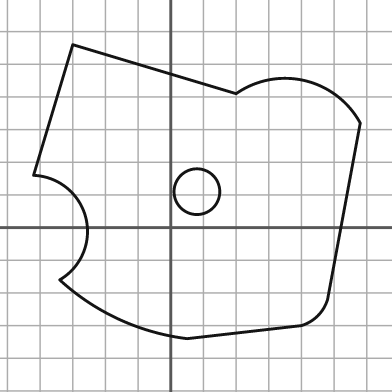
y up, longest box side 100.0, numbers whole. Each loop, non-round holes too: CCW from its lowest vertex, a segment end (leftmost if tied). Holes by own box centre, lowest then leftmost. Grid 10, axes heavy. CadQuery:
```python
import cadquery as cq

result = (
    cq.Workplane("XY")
    .moveTo(5.0, -34.0)
    .lineTo(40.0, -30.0)
    .threePointArc((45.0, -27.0), (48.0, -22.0))
    .lineTo(58.0, 32.0)
    .threePointArc((41.0, 45.0), (20.0, 41.0))
    .lineTo(-30.0, 56.0)
    .lineTo(-42.0, 16.0)
    .threePointArc((-26.0, 3.0), (-34.0, -16.0))
    .threePointArc((-16.0, -28.0), (5.0, -34.0))
    .close()
    .moveTo(8.0, 11.0)
    .circle(7.0)
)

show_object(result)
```